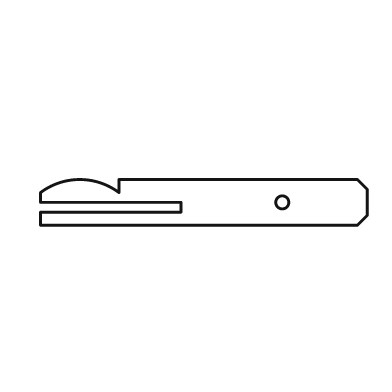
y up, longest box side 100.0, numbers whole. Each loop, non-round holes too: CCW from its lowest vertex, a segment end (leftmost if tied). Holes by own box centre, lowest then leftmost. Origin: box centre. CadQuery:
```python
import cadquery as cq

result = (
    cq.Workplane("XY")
    .moveTo(-50.0, -7.0)
    .lineTo(47.0, -7.0)
    .lineTo(50.0, -4.0)
    .lineTo(50.0, 4.0)
    .lineTo(47.0, 7.0)
    .lineTo(-26.0, 7.0)
    .lineTo(-26.0, 3.0)
    .threePointArc((-38.0, 7.0), (-50.0, 3.0))
    .lineTo(-50.0, 0.0)
    .lineTo(-7.0, 0.0)
    .lineTo(-7.0, -3.0)
    .lineTo(-50.0, -3.0)
    .close()
    .moveTo(24.0, 0.0)
    .circle(2.0)
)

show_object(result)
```